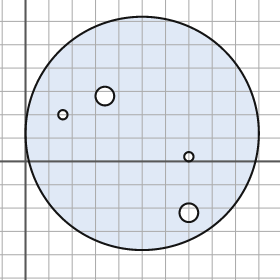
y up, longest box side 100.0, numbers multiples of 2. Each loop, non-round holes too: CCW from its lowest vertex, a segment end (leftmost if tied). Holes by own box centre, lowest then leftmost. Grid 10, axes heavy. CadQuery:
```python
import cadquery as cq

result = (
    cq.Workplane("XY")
    .moveTo(50.0, 12.0)
    .circle(50.0)
    .moveTo(70.0, -22.0)
    .circle(4.0)
    .moveTo(70.0, 2.0)
    .circle(2.0)
    .moveTo(16.0, 20.0)
    .circle(2.0)
    .moveTo(34.0, 28.0)
    .circle(4.0)
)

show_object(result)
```